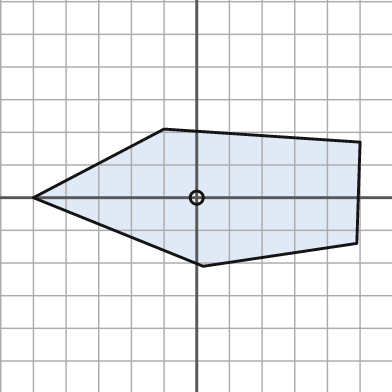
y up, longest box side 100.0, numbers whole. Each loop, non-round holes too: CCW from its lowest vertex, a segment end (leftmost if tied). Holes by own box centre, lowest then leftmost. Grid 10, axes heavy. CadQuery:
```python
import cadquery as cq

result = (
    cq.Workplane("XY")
    .moveTo(2.0, -21.0)
    .lineTo(49.0, -14.0)
    .lineTo(50.0, 17.0)
    .lineTo(-10.0, 21.0)
    .lineTo(-50.0, 0.0)
    .close()
    .moveTo(0.0, 0.0)
    .circle(2.0)
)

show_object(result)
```